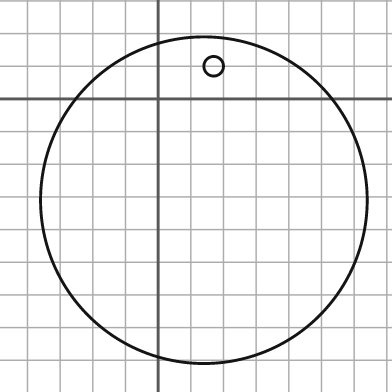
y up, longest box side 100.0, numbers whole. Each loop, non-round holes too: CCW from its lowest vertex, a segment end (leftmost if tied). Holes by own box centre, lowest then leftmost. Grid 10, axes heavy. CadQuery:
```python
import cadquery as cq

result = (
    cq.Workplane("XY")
    .moveTo(14.0, -31.0)
    .circle(50.0)
    .moveTo(17.0, 10.0)
    .circle(3.0)
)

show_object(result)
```